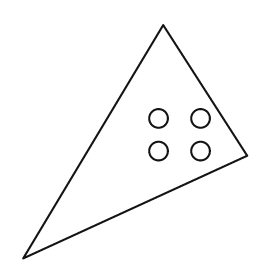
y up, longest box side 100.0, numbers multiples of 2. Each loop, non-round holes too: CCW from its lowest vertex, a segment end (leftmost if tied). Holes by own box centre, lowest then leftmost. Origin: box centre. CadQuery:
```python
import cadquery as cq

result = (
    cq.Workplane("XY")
    .moveTo(-48.0, -50.0)
    .lineTo(48.0, -6.0)
    .lineTo(12.0, 50.0)
    .close()
    .moveTo(10.0, -4.0)
    .circle(4.0)
    .moveTo(28.0, -4.0)
    .circle(4.0)
    .moveTo(10.0, 10.0)
    .circle(4.0)
    .moveTo(28.0, 10.0)
    .circle(4.0)
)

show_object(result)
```